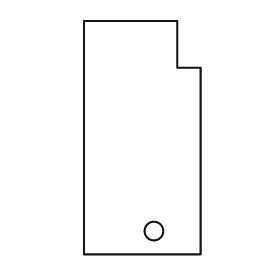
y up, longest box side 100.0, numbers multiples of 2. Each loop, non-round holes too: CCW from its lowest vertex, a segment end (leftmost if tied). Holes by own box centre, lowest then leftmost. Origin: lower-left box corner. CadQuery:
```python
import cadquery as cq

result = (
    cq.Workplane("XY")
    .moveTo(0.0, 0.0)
    .lineTo(50.0, 0.0)
    .lineTo(50.0, 80.0)
    .lineTo(40.0, 80.0)
    .lineTo(40.0, 100.0)
    .lineTo(0.0, 100.0)
    .close()
    .moveTo(30.0, 10.0)
    .circle(4.0)
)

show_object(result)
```